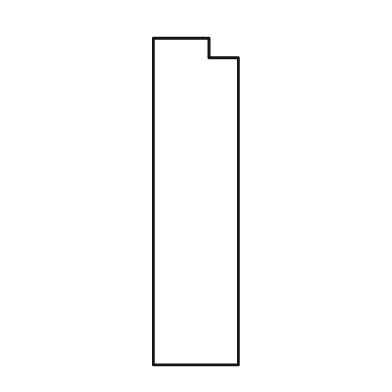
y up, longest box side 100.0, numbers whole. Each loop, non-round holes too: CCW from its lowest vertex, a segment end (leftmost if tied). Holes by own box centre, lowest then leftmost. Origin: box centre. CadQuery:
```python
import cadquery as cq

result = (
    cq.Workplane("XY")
    .moveTo(-13.0, -50.0)
    .lineTo(13.0, -50.0)
    .lineTo(13.0, 44.0)
    .lineTo(4.0, 44.0)
    .lineTo(4.0, 50.0)
    .lineTo(-13.0, 50.0)
    .close()
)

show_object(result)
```